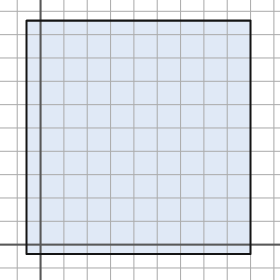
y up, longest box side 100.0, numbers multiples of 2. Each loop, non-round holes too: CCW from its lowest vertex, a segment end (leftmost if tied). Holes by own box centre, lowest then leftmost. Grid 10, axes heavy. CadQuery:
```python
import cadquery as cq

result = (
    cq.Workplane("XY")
    .moveTo(-6.0, -4.0)
    .lineTo(90.0, -4.0)
    .lineTo(90.0, 96.0)
    .lineTo(-6.0, 96.0)
    .close()
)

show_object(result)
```